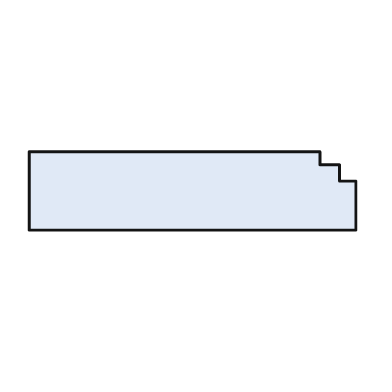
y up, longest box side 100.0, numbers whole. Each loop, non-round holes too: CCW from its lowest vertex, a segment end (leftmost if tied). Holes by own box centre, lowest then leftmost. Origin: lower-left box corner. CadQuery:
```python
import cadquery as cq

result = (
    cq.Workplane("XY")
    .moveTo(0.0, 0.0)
    .lineTo(100.0, 0.0)
    .lineTo(100.0, 15.0)
    .lineTo(95.0, 15.0)
    .lineTo(95.0, 20.0)
    .lineTo(89.0, 20.0)
    .lineTo(89.0, 24.0)
    .lineTo(0.0, 24.0)
    .close()
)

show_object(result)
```